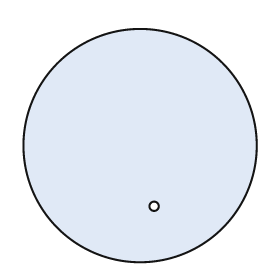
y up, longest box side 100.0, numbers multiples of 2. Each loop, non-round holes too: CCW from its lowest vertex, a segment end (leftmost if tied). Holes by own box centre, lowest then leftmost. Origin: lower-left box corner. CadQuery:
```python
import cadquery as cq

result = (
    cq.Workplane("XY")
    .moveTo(50.0, 50.0)
    .circle(50.0)
    .moveTo(56.0, 24.0)
    .circle(2.0)
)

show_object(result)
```